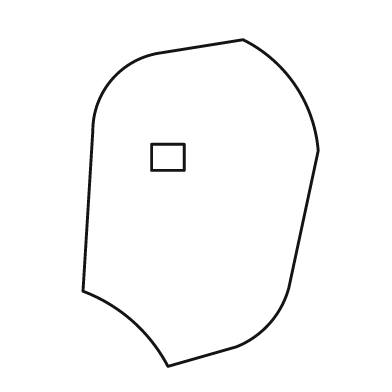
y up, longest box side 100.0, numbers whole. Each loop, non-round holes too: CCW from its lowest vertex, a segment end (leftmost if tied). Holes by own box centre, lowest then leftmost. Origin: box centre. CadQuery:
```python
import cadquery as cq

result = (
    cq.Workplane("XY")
    .moveTo(-10.0, -50.0)
    .lineTo(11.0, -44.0)
    .threePointArc((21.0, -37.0), (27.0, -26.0))
    .lineTo(36.0, 16.0)
    .threePointArc((29.0, 36.0), (13.0, 50.0))
    .lineTo(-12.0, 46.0)
    .threePointArc((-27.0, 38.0), (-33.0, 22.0))
    .lineTo(-36.0, -27.0)
    .threePointArc((-21.0, -36.0), (-10.0, -50.0))
    .close()
    .moveTo(-15.0, 10.0)
    .lineTo(-5.0, 10.0)
    .lineTo(-5.0, 18.0)
    .lineTo(-15.0, 18.0)
    .close()
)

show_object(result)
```